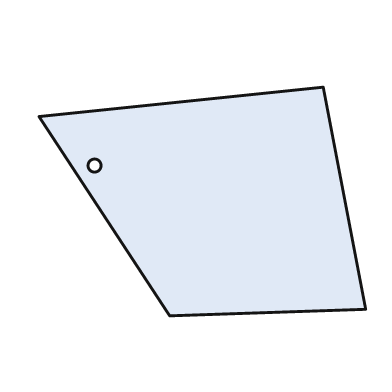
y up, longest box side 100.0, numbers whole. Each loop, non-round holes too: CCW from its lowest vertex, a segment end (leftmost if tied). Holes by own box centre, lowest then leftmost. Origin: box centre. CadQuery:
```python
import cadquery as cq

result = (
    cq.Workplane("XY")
    .moveTo(-10.0, -35.0)
    .lineTo(50.0, -33.0)
    .lineTo(37.0, 35.0)
    .lineTo(-50.0, 26.0)
    .close()
    .moveTo(-33.0, 11.0)
    .circle(2.0)
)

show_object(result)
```